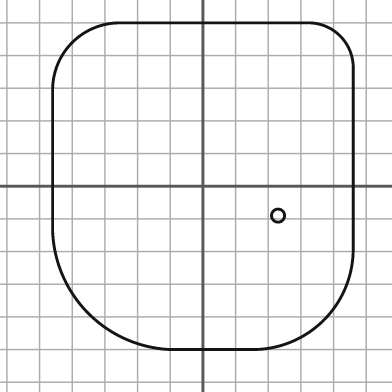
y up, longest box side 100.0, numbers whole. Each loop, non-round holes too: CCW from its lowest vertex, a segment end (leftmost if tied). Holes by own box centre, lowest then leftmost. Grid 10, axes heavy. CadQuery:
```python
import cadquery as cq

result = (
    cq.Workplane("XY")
    .moveTo(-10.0, -50.0)
    .lineTo(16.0, -50.0)
    .threePointArc((37.0, -41.0), (46.0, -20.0))
    .lineTo(46.0, 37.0)
    .threePointArc((42.0, 46.0), (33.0, 50.0))
    .lineTo(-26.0, 50.0)
    .threePointArc((-40.0, 44.0), (-46.0, 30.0))
    .lineTo(-46.0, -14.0)
    .threePointArc((-35.0, -39.0), (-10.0, -50.0))
    .close()
    .moveTo(23.0, -9.0)
    .circle(2.0)
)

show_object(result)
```